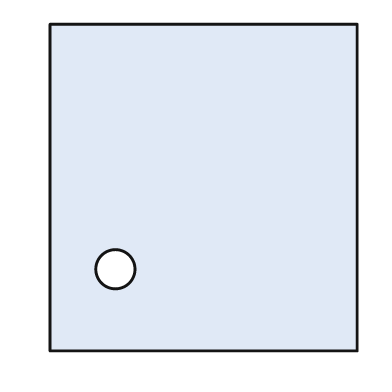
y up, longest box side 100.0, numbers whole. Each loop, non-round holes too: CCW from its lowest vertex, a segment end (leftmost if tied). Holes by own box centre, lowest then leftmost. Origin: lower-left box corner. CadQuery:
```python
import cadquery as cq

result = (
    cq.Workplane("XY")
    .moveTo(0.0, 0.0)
    .lineTo(94.0, 0.0)
    .lineTo(94.0, 100.0)
    .lineTo(0.0, 100.0)
    .close()
    .moveTo(20.0, 25.0)
    .circle(6.0)
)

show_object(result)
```